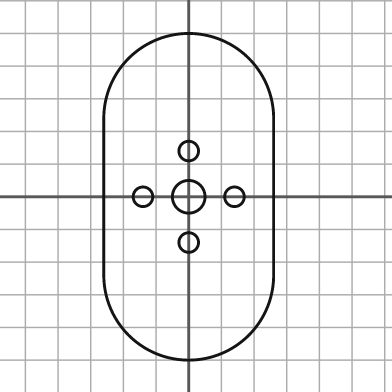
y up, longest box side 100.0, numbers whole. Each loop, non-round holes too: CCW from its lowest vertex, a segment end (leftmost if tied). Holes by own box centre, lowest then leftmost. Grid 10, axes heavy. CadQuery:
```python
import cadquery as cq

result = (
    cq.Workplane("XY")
    .moveTo(-26.0, -24.0)
    .threePointArc((0.0, -50.0), (26.0, -24.0))
    .lineTo(26.0, 24.0)
    .threePointArc((0.0, 50.0), (-26.0, 24.0))
    .close()
    .moveTo(0.0, -14.0)
    .circle(3.0)
    .moveTo(-14.0, 0.0)
    .circle(3.0)
    .moveTo(0.0, 0.0)
    .circle(5.0)
    .moveTo(14.0, 0.0)
    .circle(3.0)
    .moveTo(0.0, 14.0)
    .circle(3.0)
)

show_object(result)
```